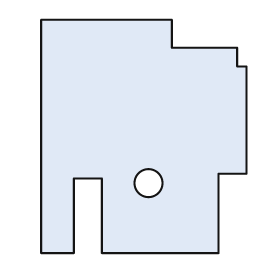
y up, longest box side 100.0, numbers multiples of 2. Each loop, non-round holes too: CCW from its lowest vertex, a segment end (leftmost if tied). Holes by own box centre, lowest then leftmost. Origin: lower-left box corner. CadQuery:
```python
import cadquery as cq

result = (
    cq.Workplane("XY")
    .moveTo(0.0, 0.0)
    .lineTo(14.0, 0.0)
    .lineTo(14.0, 32.0)
    .lineTo(26.0, 32.0)
    .lineTo(26.0, 0.0)
    .lineTo(76.0, 0.0)
    .lineTo(76.0, 34.0)
    .lineTo(88.0, 34.0)
    .lineTo(88.0, 80.0)
    .lineTo(84.0, 80.0)
    .lineTo(84.0, 88.0)
    .lineTo(56.0, 88.0)
    .lineTo(56.0, 100.0)
    .lineTo(0.0, 100.0)
    .close()
    .moveTo(46.0, 30.0)
    .circle(6.0)
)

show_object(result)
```